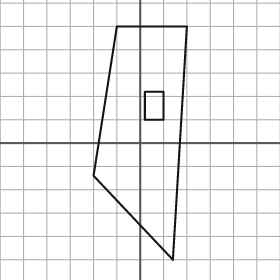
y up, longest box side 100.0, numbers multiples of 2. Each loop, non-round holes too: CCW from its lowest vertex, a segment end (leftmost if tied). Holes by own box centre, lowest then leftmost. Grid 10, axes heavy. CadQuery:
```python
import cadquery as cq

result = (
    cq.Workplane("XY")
    .moveTo(14.0, -50.0)
    .lineTo(20.0, 50.0)
    .lineTo(-10.0, 50.0)
    .lineTo(-20.0, -14.0)
    .close()
    .moveTo(2.0, 10.0)
    .lineTo(10.0, 10.0)
    .lineTo(10.0, 22.0)
    .lineTo(2.0, 22.0)
    .close()
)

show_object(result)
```